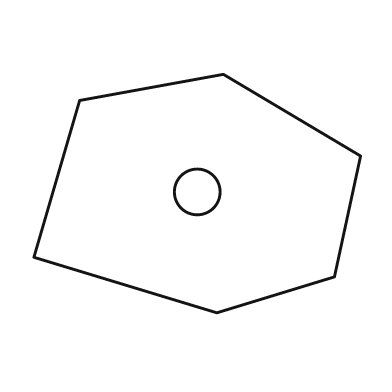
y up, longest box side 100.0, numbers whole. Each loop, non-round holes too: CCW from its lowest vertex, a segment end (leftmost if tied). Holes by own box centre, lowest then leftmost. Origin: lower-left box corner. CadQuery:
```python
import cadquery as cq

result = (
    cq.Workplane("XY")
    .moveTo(56.0, 0.0)
    .lineTo(92.0, 11.0)
    .lineTo(100.0, 48.0)
    .lineTo(58.0, 73.0)
    .lineTo(14.0, 65.0)
    .lineTo(0.0, 17.0)
    .close()
    .moveTo(50.0, 37.0)
    .circle(7.0)
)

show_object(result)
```